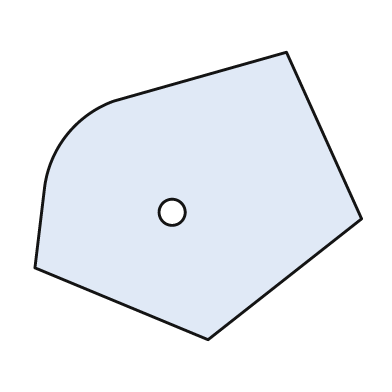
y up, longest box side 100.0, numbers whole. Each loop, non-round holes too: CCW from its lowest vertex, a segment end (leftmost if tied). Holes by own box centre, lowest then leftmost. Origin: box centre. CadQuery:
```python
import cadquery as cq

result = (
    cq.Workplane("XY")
    .moveTo(3.0, -44.0)
    .lineTo(50.0, -7.0)
    .lineTo(27.0, 44.0)
    .lineTo(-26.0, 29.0)
    .threePointArc((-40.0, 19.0), (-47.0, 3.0))
    .lineTo(-50.0, -22.0)
    .close()
    .moveTo(-8.0, -5.0)
    .circle(4.0)
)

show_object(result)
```